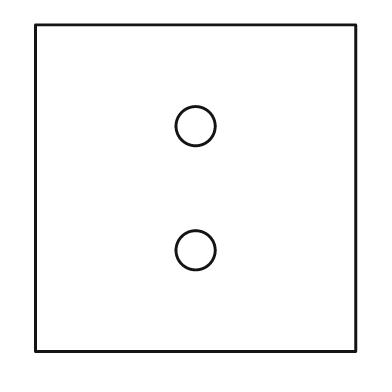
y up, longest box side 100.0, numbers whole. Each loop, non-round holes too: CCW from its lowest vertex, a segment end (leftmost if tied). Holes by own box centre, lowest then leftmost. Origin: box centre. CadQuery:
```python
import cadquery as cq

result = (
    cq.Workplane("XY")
    .moveTo(-49.0, -50.0)
    .lineTo(49.0, -50.0)
    .lineTo(49.0, 50.0)
    .lineTo(-49.0, 50.0)
    .close()
    .moveTo(0.0, -19.0)
    .circle(6.0)
    .moveTo(0.0, 19.0)
    .circle(6.0)
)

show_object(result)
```